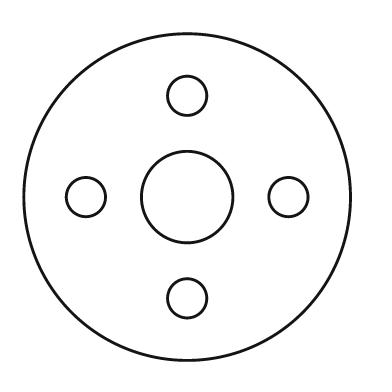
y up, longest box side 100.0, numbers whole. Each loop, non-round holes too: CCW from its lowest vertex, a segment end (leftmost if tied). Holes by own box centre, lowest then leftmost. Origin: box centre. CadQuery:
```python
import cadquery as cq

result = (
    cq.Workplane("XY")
    .moveTo(0.0, 0.0)
    .circle(50.0)
    .moveTo(0.0, -31.0)
    .circle(6.0)
    .moveTo(-31.0, 0.0)
    .circle(6.0)
    .moveTo(0.0, 0.0)
    .circle(14.0)
    .moveTo(31.0, 0.0)
    .circle(6.0)
    .moveTo(0.0, 31.0)
    .circle(6.0)
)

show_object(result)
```